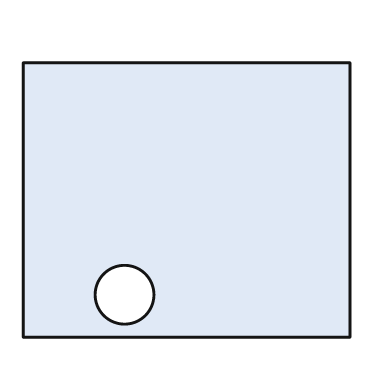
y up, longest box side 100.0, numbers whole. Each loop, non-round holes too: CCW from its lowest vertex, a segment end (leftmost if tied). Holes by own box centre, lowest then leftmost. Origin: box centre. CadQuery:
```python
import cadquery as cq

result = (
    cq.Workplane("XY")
    .moveTo(-50.0, -42.0)
    .lineTo(50.0, -42.0)
    .lineTo(50.0, 42.0)
    .lineTo(-50.0, 42.0)
    .close()
    .moveTo(-19.0, -29.0)
    .circle(9.0)
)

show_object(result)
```